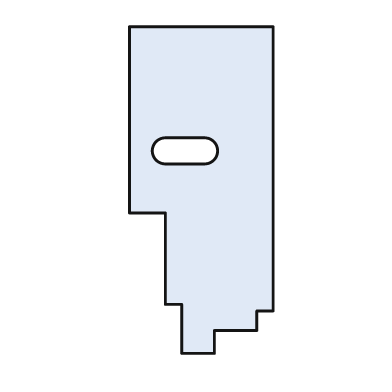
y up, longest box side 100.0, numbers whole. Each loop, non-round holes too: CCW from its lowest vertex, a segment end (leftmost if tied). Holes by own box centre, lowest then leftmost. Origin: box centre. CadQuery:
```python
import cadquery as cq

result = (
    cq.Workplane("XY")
    .moveTo(-6.0, -50.0)
    .lineTo(4.0, -50.0)
    .lineTo(4.0, -43.0)
    .lineTo(17.0, -43.0)
    .lineTo(17.0, -37.0)
    .lineTo(22.0, -37.0)
    .lineTo(22.0, 50.0)
    .lineTo(-22.0, 50.0)
    .lineTo(-22.0, -7.0)
    .lineTo(-11.0, -7.0)
    .lineTo(-11.0, -35.0)
    .lineTo(-6.0, -35.0)
    .close()
    .moveTo(-11.0, 8.0)
    .lineTo(1.0, 8.0)
    .threePointArc((5.0, 12.0), (1.0, 16.0))
    .lineTo(-11.0, 16.0)
    .threePointArc((-15.0, 12.0), (-11.0, 8.0))
    .close()
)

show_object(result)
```